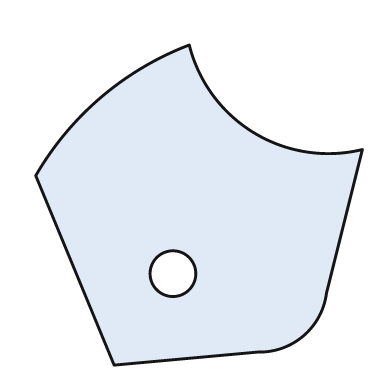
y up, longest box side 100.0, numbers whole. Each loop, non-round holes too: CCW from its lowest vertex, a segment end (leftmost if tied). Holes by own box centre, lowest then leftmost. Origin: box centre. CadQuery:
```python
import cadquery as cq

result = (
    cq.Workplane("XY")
    .moveTo(-26.0, -49.0)
    .lineTo(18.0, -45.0)
    .threePointArc((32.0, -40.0), (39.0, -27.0))
    .lineTo(50.0, 17.0)
    .threePointArc((17.0, 22.0), (-3.0, 49.0))
    .threePointArc((-30.0, 33.0), (-50.0, 9.0))
    .close()
    .moveTo(-8.0, -21.0)
    .circle(7.0)
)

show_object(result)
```